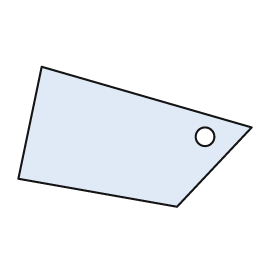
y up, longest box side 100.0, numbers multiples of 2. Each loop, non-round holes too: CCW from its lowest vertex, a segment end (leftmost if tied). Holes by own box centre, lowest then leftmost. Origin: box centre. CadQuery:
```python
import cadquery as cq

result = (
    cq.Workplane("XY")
    .moveTo(18.0, -30.0)
    .lineTo(50.0, 4.0)
    .lineTo(-40.0, 30.0)
    .lineTo(-50.0, -18.0)
    .close()
    .moveTo(30.0, 0.0)
    .circle(4.0)
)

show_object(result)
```